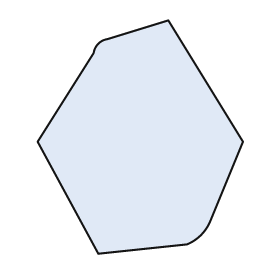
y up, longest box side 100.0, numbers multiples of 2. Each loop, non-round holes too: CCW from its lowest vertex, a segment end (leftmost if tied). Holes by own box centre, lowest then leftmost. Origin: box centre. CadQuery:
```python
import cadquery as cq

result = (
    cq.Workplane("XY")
    .moveTo(-18.0, -50.0)
    .lineTo(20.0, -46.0)
    .threePointArc((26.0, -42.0), (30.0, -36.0))
    .lineTo(44.0, -2.0)
    .lineTo(12.0, 50.0)
    .lineTo(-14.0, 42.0)
    .threePointArc((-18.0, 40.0), (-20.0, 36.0))
    .lineTo(-44.0, -2.0)
    .close()
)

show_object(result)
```